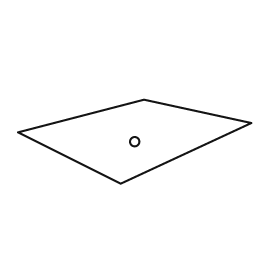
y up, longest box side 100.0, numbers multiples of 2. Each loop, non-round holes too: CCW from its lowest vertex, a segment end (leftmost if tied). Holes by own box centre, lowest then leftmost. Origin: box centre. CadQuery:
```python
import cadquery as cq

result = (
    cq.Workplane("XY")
    .moveTo(-6.0, -18.0)
    .lineTo(50.0, 8.0)
    .lineTo(4.0, 18.0)
    .lineTo(-50.0, 4.0)
    .close()
    .moveTo(0.0, 0.0)
    .circle(2.0)
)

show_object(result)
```